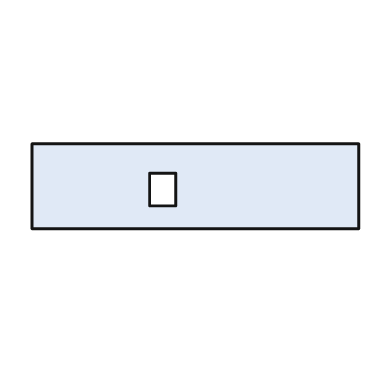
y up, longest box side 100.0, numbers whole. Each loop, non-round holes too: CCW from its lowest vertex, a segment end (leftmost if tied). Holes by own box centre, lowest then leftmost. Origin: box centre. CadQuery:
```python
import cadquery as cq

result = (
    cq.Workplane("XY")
    .moveTo(-50.0, -13.0)
    .lineTo(50.0, -13.0)
    .lineTo(50.0, 13.0)
    .lineTo(-50.0, 13.0)
    .close()
    .moveTo(-14.0, -6.0)
    .lineTo(-6.0, -6.0)
    .lineTo(-6.0, 4.0)
    .lineTo(-14.0, 4.0)
    .close()
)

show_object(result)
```